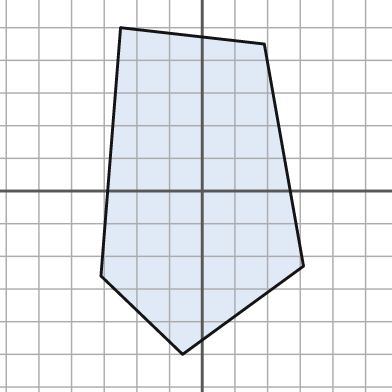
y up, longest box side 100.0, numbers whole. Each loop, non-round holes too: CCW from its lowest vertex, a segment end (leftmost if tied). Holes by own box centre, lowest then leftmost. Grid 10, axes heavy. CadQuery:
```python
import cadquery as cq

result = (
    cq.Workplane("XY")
    .moveTo(-6.0, -50.0)
    .lineTo(31.0, -23.0)
    .lineTo(19.0, 45.0)
    .lineTo(-25.0, 50.0)
    .lineTo(-31.0, -26.0)
    .close()
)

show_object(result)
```